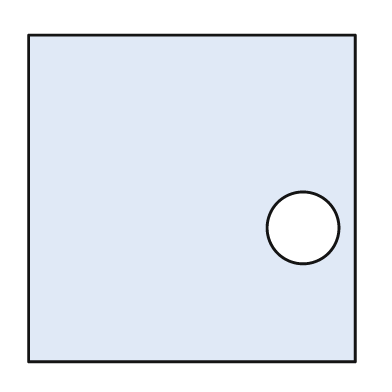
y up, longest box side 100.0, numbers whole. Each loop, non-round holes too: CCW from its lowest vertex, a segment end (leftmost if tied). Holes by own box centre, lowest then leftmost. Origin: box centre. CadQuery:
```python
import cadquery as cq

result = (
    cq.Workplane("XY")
    .moveTo(-50.0, -50.0)
    .lineTo(50.0, -50.0)
    .lineTo(50.0, 50.0)
    .lineTo(-50.0, 50.0)
    .close()
    .moveTo(34.0, -9.0)
    .circle(11.0)
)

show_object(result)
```